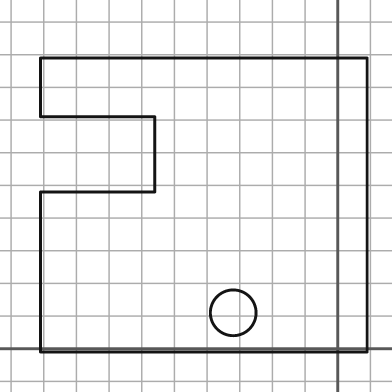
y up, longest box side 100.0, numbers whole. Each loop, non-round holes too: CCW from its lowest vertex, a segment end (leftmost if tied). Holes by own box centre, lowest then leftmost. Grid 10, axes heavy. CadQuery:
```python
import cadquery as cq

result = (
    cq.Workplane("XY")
    .moveTo(-91.0, -1.0)
    .lineTo(9.0, -1.0)
    .lineTo(9.0, 89.0)
    .lineTo(-91.0, 89.0)
    .lineTo(-91.0, 71.0)
    .lineTo(-56.0, 71.0)
    .lineTo(-56.0, 48.0)
    .lineTo(-91.0, 48.0)
    .close()
    .moveTo(-32.0, 11.0)
    .circle(7.0)
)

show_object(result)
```